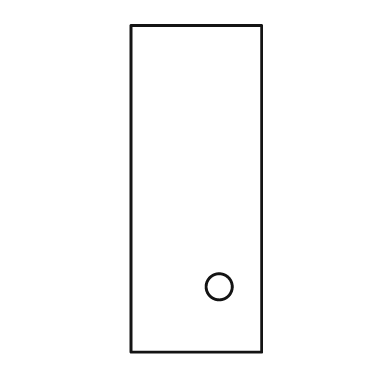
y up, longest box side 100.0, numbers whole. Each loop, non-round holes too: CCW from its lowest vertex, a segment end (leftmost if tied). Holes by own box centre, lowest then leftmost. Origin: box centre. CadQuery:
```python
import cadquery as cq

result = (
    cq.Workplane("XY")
    .moveTo(-20.0, -50.0)
    .lineTo(20.0, -50.0)
    .lineTo(20.0, 50.0)
    .lineTo(-20.0, 50.0)
    .close()
    .moveTo(7.0, -30.0)
    .circle(4.0)
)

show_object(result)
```